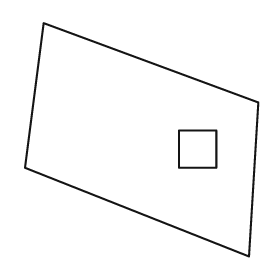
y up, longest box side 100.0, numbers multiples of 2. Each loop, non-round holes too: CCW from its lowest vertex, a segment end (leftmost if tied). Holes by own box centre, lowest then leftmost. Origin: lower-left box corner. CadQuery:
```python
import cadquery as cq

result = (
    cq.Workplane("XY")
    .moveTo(96.0, 0.0)
    .lineTo(100.0, 66.0)
    .lineTo(8.0, 100.0)
    .lineTo(0.0, 38.0)
    .close()
    .moveTo(66.0, 38.0)
    .lineTo(82.0, 38.0)
    .lineTo(82.0, 54.0)
    .lineTo(66.0, 54.0)
    .close()
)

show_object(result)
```